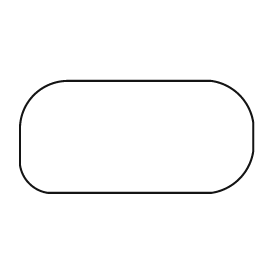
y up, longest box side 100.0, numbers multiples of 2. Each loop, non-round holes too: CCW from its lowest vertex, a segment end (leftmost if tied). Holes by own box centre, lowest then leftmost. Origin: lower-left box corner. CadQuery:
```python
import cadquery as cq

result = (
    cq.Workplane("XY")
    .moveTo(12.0, 0.0)
    .lineTo(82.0, 0.0)
    .threePointArc((94.0, 6.0), (100.0, 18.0))
    .lineTo(100.0, 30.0)
    .threePointArc((94.0, 42.0), (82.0, 48.0))
    .lineTo(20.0, 48.0)
    .threePointArc((6.0, 42.0), (0.0, 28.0))
    .lineTo(0.0, 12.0)
    .threePointArc((4.0, 4.0), (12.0, 0.0))
    .close()
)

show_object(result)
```